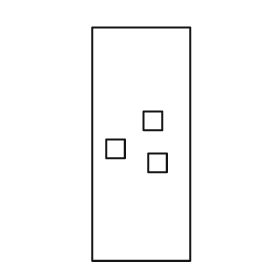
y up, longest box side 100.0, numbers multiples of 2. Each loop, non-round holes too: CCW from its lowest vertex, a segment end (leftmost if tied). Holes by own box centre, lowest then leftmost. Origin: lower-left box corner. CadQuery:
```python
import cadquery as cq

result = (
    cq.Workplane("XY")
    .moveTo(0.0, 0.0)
    .lineTo(42.0, 0.0)
    .lineTo(42.0, 100.0)
    .lineTo(0.0, 100.0)
    .close()
    .moveTo(24.0, 38.0)
    .lineTo(32.0, 38.0)
    .lineTo(32.0, 46.0)
    .lineTo(24.0, 46.0)
    .close()
    .moveTo(6.0, 44.0)
    .lineTo(14.0, 44.0)
    .lineTo(14.0, 52.0)
    .lineTo(6.0, 52.0)
    .close()
    .moveTo(22.0, 56.0)
    .lineTo(30.0, 56.0)
    .lineTo(30.0, 64.0)
    .lineTo(22.0, 64.0)
    .close()
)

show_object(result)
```